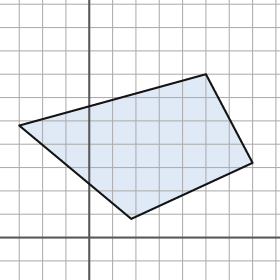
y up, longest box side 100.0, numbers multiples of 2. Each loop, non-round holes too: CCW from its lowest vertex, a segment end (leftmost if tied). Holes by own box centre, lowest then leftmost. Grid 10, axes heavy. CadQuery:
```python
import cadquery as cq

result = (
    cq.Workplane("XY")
    .moveTo(18.0, 8.0)
    .lineTo(70.0, 32.0)
    .lineTo(50.0, 70.0)
    .lineTo(-30.0, 48.0)
    .close()
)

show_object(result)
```